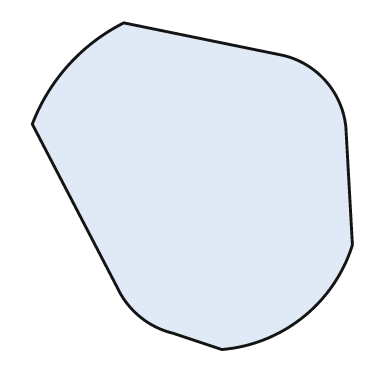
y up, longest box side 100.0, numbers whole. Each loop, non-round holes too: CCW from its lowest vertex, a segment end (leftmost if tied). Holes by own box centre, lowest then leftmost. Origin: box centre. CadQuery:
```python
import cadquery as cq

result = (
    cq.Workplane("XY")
    .moveTo(9.0, -50.0)
    .threePointArc((34.0, -40.0), (49.0, -18.0))
    .lineTo(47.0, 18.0)
    .threePointArc((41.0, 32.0), (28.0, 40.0))
    .lineTo(-21.0, 50.0)
    .threePointArc((-38.0, 37.0), (-49.0, 19.0))
    .lineTo(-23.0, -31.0)
    .threePointArc((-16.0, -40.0), (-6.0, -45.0))
    .close()
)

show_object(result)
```